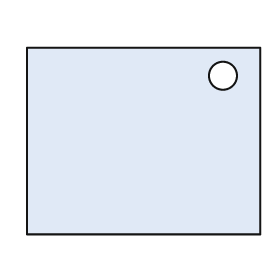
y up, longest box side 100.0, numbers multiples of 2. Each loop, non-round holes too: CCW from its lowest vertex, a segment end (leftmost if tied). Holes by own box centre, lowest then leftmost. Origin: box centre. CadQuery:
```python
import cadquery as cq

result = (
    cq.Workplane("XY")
    .moveTo(-50.0, -40.0)
    .lineTo(50.0, -40.0)
    .lineTo(50.0, 40.0)
    .lineTo(-50.0, 40.0)
    .close()
    .moveTo(34.0, 28.0)
    .circle(6.0)
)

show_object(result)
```